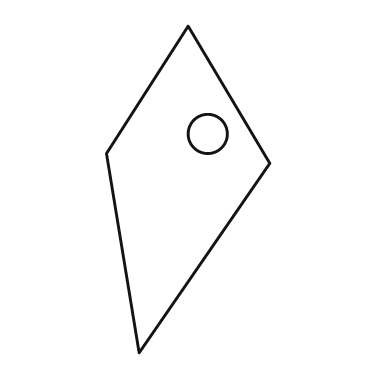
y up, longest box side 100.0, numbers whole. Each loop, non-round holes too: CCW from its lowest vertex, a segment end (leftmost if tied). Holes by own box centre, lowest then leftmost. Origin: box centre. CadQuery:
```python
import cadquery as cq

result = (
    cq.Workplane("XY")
    .moveTo(-15.0, -50.0)
    .lineTo(25.0, 8.0)
    .lineTo(0.0, 50.0)
    .lineTo(-25.0, 11.0)
    .close()
    .moveTo(6.0, 17.0)
    .circle(6.0)
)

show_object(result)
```